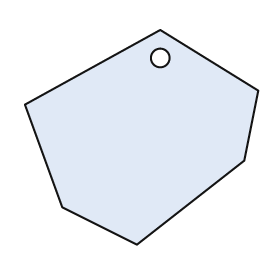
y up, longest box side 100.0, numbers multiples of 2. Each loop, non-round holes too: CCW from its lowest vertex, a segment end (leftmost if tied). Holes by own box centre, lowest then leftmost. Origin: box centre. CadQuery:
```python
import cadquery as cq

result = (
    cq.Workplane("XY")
    .moveTo(-2.0, -46.0)
    .lineTo(44.0, -10.0)
    .lineTo(50.0, 20.0)
    .lineTo(8.0, 46.0)
    .lineTo(-50.0, 14.0)
    .lineTo(-34.0, -30.0)
    .close()
    .moveTo(8.0, 34.0)
    .circle(4.0)
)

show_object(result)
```